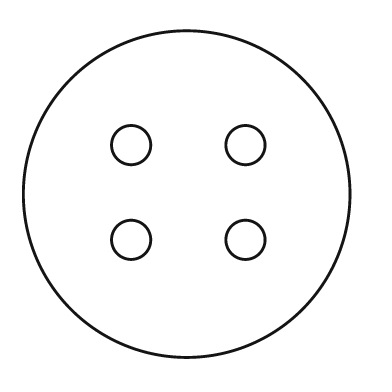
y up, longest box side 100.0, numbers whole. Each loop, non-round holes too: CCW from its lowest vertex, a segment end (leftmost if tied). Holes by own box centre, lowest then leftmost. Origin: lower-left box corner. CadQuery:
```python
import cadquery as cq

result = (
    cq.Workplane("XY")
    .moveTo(50.0, 50.0)
    .circle(50.0)
    .moveTo(33.0, 36.0)
    .circle(6.0)
    .moveTo(68.0, 36.0)
    .circle(6.0)
    .moveTo(33.0, 65.0)
    .circle(6.0)
    .moveTo(68.0, 65.0)
    .circle(6.0)
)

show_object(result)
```